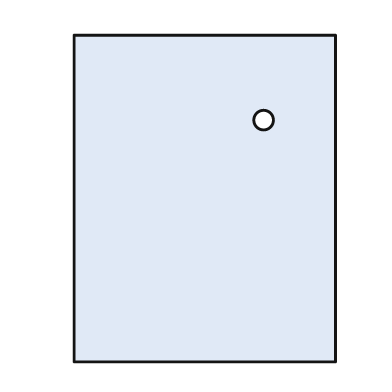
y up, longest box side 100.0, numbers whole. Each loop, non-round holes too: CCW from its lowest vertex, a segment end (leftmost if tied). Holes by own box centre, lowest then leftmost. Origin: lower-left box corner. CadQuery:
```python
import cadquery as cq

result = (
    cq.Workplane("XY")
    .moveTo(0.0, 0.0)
    .lineTo(80.0, 0.0)
    .lineTo(80.0, 100.0)
    .lineTo(0.0, 100.0)
    .close()
    .moveTo(58.0, 74.0)
    .circle(3.0)
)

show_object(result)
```